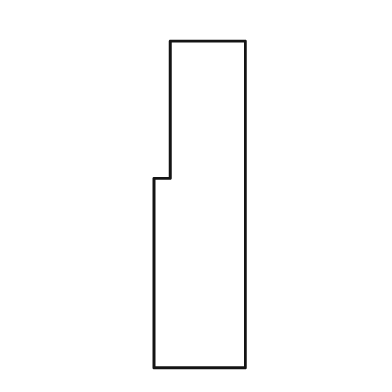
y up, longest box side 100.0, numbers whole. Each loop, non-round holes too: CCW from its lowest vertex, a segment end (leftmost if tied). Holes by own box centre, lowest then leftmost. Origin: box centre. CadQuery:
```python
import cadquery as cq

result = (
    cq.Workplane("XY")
    .moveTo(-14.0, -50.0)
    .lineTo(14.0, -50.0)
    .lineTo(14.0, 50.0)
    .lineTo(-9.0, 50.0)
    .lineTo(-9.0, 8.0)
    .lineTo(-14.0, 8.0)
    .close()
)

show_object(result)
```